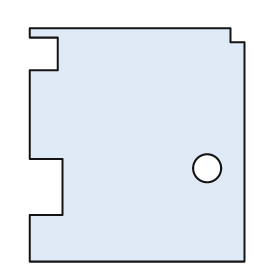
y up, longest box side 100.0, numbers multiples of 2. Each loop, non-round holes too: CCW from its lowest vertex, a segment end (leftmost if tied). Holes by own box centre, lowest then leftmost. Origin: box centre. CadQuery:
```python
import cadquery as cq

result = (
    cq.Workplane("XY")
    .moveTo(-46.0, -50.0)
    .lineTo(46.0, -50.0)
    .lineTo(46.0, 44.0)
    .lineTo(40.0, 44.0)
    .lineTo(40.0, 50.0)
    .lineTo(-46.0, 50.0)
    .lineTo(-46.0, 46.0)
    .lineTo(-34.0, 46.0)
    .lineTo(-34.0, 32.0)
    .lineTo(-46.0, 32.0)
    .lineTo(-46.0, -6.0)
    .lineTo(-32.0, -6.0)
    .lineTo(-32.0, -30.0)
    .lineTo(-46.0, -30.0)
    .close()
    .moveTo(30.0, -10.0)
    .circle(6.0)
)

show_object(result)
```